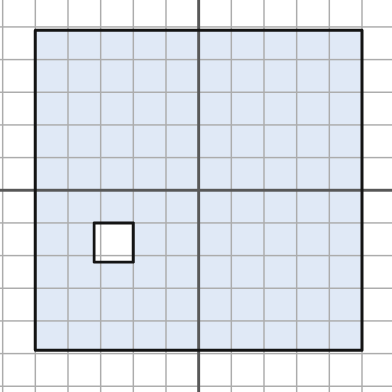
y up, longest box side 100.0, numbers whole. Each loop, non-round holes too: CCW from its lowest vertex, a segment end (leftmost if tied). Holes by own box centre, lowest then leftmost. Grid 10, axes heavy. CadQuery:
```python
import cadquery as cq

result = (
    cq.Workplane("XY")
    .moveTo(-50.0, -49.0)
    .lineTo(50.0, -49.0)
    .lineTo(50.0, 49.0)
    .lineTo(-50.0, 49.0)
    .close()
    .moveTo(-32.0, -22.0)
    .lineTo(-20.0, -22.0)
    .lineTo(-20.0, -10.0)
    .lineTo(-32.0, -10.0)
    .close()
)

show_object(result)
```